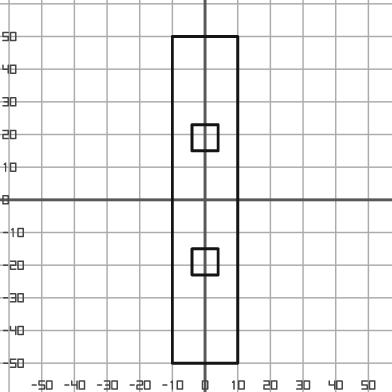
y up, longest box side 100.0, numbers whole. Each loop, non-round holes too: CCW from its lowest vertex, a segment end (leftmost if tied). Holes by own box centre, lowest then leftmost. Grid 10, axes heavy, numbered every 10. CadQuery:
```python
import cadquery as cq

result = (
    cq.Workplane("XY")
    .moveTo(-10.0, -50.0)
    .lineTo(10.0, -50.0)
    .lineTo(10.0, 50.0)
    .lineTo(-10.0, 50.0)
    .close()
    .moveTo(-4.0, -23.0)
    .lineTo(4.0, -23.0)
    .lineTo(4.0, -15.0)
    .lineTo(-4.0, -15.0)
    .close()
    .moveTo(-4.0, 15.0)
    .lineTo(4.0, 15.0)
    .lineTo(4.0, 23.0)
    .lineTo(-4.0, 23.0)
    .close()
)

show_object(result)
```